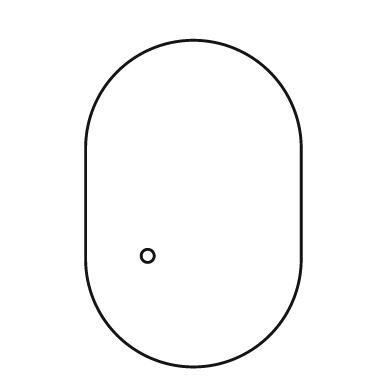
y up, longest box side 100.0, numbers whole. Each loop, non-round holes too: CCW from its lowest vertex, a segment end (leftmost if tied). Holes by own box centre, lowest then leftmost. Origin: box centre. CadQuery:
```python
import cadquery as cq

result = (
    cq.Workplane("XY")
    .moveTo(-33.0, -17.0)
    .threePointArc((0.0, -50.0), (33.0, -17.0))
    .lineTo(33.0, 17.0)
    .threePointArc((0.0, 50.0), (-33.0, 17.0))
    .close()
    .moveTo(-14.0, -16.0)
    .circle(2.0)
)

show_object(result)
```